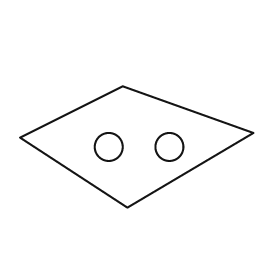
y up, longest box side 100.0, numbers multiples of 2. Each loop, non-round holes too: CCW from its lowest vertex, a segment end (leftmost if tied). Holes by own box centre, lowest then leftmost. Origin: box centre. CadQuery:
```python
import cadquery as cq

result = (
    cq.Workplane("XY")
    .moveTo(-4.0, -26.0)
    .lineTo(50.0, 6.0)
    .lineTo(-6.0, 26.0)
    .lineTo(-50.0, 4.0)
    .close()
    .moveTo(-12.0, 0.0)
    .circle(6.0)
    .moveTo(14.0, 0.0)
    .circle(6.0)
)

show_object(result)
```